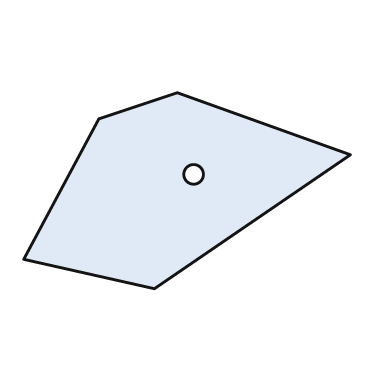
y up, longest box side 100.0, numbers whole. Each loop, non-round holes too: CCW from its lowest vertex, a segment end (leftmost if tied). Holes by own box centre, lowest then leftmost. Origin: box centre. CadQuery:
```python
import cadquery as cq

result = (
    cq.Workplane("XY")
    .moveTo(-10.0, -30.0)
    .lineTo(50.0, 11.0)
    .lineTo(-3.0, 30.0)
    .lineTo(-27.0, 22.0)
    .lineTo(-50.0, -21.0)
    .close()
    .moveTo(2.0, 5.0)
    .circle(3.0)
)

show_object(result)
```